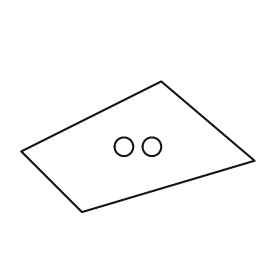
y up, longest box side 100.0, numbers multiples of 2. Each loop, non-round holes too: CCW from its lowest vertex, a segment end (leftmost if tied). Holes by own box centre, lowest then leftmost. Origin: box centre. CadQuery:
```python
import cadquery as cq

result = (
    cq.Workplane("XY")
    .moveTo(-24.0, -28.0)
    .lineTo(50.0, -6.0)
    .lineTo(10.0, 28.0)
    .lineTo(-50.0, -2.0)
    .close()
    .moveTo(-6.0, 0.0)
    .circle(4.0)
    .moveTo(6.0, 0.0)
    .circle(4.0)
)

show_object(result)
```